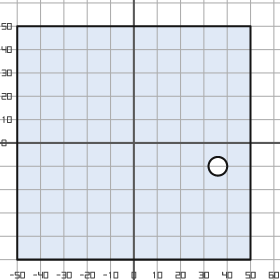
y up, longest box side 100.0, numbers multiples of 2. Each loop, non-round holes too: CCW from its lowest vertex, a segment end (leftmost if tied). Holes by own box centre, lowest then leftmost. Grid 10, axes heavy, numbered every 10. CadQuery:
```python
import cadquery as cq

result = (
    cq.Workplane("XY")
    .moveTo(-50.0, -50.0)
    .lineTo(50.0, -50.0)
    .lineTo(50.0, 50.0)
    .lineTo(-50.0, 50.0)
    .close()
    .moveTo(36.0, -10.0)
    .circle(4.0)
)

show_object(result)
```